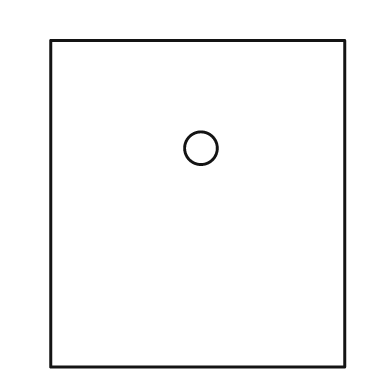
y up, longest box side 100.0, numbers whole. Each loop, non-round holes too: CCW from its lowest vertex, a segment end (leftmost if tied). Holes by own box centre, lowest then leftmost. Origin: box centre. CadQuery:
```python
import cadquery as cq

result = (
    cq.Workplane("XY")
    .moveTo(-45.0, -50.0)
    .lineTo(45.0, -50.0)
    .lineTo(45.0, 50.0)
    .lineTo(-45.0, 50.0)
    .close()
    .moveTo(1.0, 17.0)
    .circle(5.0)
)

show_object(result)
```